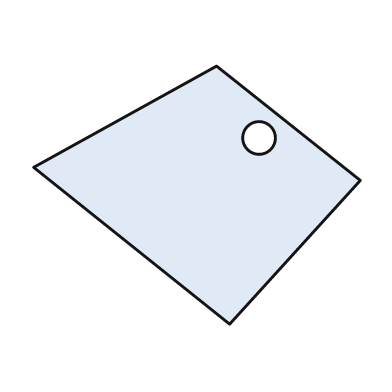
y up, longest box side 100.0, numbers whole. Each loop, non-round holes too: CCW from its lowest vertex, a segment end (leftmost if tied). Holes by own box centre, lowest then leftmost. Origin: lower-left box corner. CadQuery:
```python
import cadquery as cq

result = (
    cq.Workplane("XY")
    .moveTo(60.0, 0.0)
    .lineTo(100.0, 44.0)
    .lineTo(56.0, 79.0)
    .lineTo(0.0, 48.0)
    .close()
    .moveTo(69.0, 57.0)
    .circle(5.0)
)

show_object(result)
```